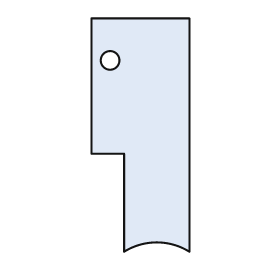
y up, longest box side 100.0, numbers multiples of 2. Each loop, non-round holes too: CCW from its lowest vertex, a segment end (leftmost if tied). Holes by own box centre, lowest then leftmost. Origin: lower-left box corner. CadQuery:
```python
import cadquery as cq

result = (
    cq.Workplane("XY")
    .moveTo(14.0, 0.0)
    .threePointArc((28.0, 4.0), (42.0, 0.0))
    .lineTo(42.0, 100.0)
    .lineTo(0.0, 100.0)
    .lineTo(0.0, 42.0)
    .lineTo(14.0, 42.0)
    .close()
    .moveTo(8.0, 82.0)
    .circle(4.0)
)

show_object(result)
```